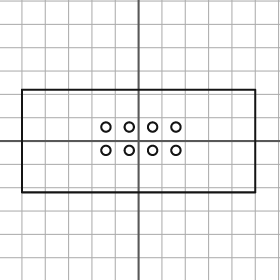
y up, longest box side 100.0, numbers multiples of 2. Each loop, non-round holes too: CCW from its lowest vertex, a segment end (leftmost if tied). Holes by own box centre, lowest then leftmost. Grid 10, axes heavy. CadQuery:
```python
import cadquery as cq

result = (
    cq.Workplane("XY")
    .moveTo(-50.0, -22.0)
    .lineTo(50.0, -22.0)
    .lineTo(50.0, 22.0)
    .lineTo(-50.0, 22.0)
    .close()
    .moveTo(-14.0, -4.0)
    .circle(2.0)
    .moveTo(-4.0, -4.0)
    .circle(2.0)
    .moveTo(6.0, -4.0)
    .circle(2.0)
    .moveTo(16.0, -4.0)
    .circle(2.0)
    .moveTo(-14.0, 6.0)
    .circle(2.0)
    .moveTo(-4.0, 6.0)
    .circle(2.0)
    .moveTo(6.0, 6.0)
    .circle(2.0)
    .moveTo(16.0, 6.0)
    .circle(2.0)
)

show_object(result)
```